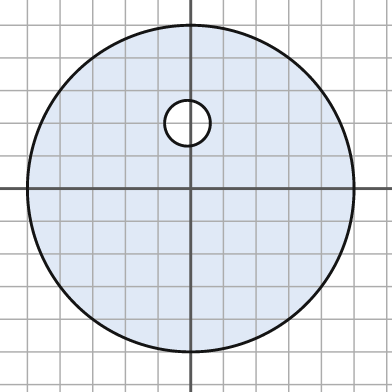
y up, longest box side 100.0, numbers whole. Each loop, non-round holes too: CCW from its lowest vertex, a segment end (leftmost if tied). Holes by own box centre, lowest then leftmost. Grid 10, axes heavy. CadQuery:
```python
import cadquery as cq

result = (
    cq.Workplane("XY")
    .moveTo(0.0, 0.0)
    .circle(50.0)
    .moveTo(-1.0, 20.0)
    .circle(7.0)
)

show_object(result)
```